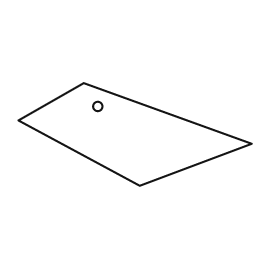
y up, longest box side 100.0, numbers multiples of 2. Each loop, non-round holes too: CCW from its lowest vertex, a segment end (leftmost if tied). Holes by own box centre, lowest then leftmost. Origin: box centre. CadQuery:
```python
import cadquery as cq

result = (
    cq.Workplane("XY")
    .moveTo(2.0, -22.0)
    .lineTo(50.0, -4.0)
    .lineTo(-22.0, 22.0)
    .lineTo(-50.0, 6.0)
    .close()
    .moveTo(-16.0, 12.0)
    .circle(2.0)
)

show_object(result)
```